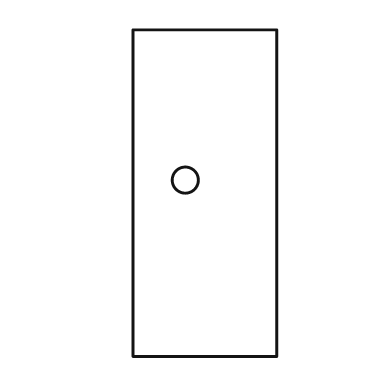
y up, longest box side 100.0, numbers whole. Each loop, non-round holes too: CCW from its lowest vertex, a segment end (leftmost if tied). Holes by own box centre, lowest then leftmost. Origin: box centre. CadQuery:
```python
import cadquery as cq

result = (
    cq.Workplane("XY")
    .moveTo(-22.0, -50.0)
    .lineTo(22.0, -50.0)
    .lineTo(22.0, 50.0)
    .lineTo(-22.0, 50.0)
    .close()
    .moveTo(-6.0, 4.0)
    .circle(4.0)
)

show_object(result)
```